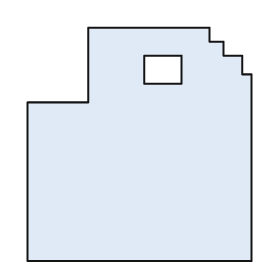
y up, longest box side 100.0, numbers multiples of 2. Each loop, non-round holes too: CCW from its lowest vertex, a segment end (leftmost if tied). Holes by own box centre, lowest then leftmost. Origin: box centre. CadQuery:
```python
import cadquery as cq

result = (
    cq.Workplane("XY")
    .moveTo(-48.0, -50.0)
    .lineTo(48.0, -50.0)
    .lineTo(48.0, 30.0)
    .lineTo(44.0, 30.0)
    .lineTo(44.0, 38.0)
    .lineTo(36.0, 38.0)
    .lineTo(36.0, 44.0)
    .lineTo(30.0, 44.0)
    .lineTo(30.0, 50.0)
    .lineTo(-22.0, 50.0)
    .lineTo(-22.0, 18.0)
    .lineTo(-48.0, 18.0)
    .close()
    .moveTo(2.0, 26.0)
    .lineTo(18.0, 26.0)
    .lineTo(18.0, 38.0)
    .lineTo(2.0, 38.0)
    .close()
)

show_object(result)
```